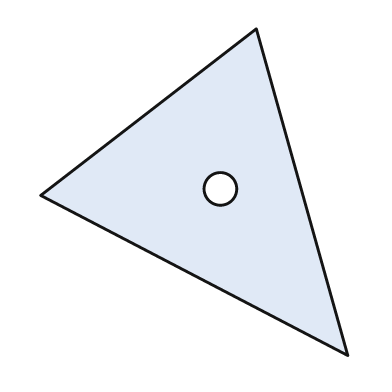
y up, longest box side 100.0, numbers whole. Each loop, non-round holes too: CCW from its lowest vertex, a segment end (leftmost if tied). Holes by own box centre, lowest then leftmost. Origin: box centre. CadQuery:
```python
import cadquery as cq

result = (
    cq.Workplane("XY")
    .moveTo(47.0, -50.0)
    .lineTo(19.0, 50.0)
    .lineTo(-47.0, -1.0)
    .close()
    .moveTo(8.0, 1.0)
    .circle(5.0)
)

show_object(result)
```